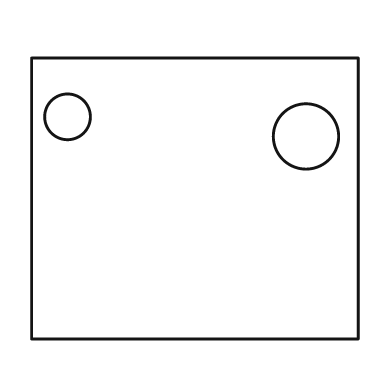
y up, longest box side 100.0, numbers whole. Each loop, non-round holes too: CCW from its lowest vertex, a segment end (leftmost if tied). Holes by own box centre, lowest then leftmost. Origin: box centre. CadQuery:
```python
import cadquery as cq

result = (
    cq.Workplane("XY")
    .moveTo(-50.0, -43.0)
    .lineTo(50.0, -43.0)
    .lineTo(50.0, 43.0)
    .lineTo(-50.0, 43.0)
    .close()
    .moveTo(34.0, 19.0)
    .circle(10.0)
    .moveTo(-39.0, 25.0)
    .circle(7.0)
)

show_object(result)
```